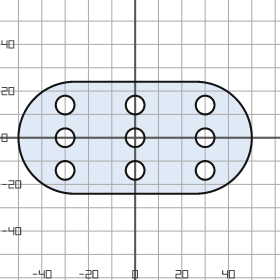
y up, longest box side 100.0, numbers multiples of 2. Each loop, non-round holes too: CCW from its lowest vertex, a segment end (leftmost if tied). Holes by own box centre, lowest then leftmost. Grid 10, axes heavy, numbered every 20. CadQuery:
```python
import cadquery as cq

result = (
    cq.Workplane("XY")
    .moveTo(-26.0, -24.0)
    .lineTo(26.0, -24.0)
    .threePointArc((50.0, 0.0), (26.0, 24.0))
    .lineTo(-26.0, 24.0)
    .threePointArc((-50.0, 0.0), (-26.0, -24.0))
    .close()
    .moveTo(-30.0, -14.0)
    .circle(4.0)
    .moveTo(0.0, -14.0)
    .circle(4.0)
    .moveTo(30.0, -14.0)
    .circle(4.0)
    .moveTo(-30.0, 0.0)
    .circle(4.0)
    .moveTo(0.0, 0.0)
    .circle(4.0)
    .moveTo(30.0, 0.0)
    .circle(4.0)
    .moveTo(-30.0, 14.0)
    .circle(4.0)
    .moveTo(0.0, 14.0)
    .circle(4.0)
    .moveTo(30.0, 14.0)
    .circle(4.0)
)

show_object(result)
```